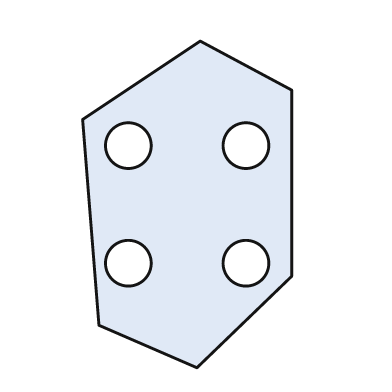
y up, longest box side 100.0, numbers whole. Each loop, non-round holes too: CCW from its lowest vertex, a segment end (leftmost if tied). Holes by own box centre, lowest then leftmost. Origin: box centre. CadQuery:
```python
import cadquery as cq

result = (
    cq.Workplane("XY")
    .moveTo(3.0, -50.0)
    .lineTo(32.0, -22.0)
    .lineTo(32.0, 35.0)
    .lineTo(4.0, 50.0)
    .lineTo(-32.0, 26.0)
    .lineTo(-27.0, -37.0)
    .close()
    .moveTo(-18.0, -18.0)
    .circle(7.0)
    .moveTo(18.0, -18.0)
    .circle(7.0)
    .moveTo(-18.0, 18.0)
    .circle(7.0)
    .moveTo(18.0, 18.0)
    .circle(7.0)
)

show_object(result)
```